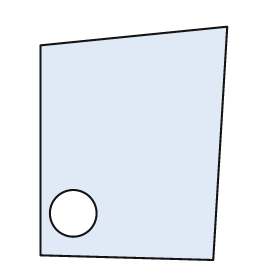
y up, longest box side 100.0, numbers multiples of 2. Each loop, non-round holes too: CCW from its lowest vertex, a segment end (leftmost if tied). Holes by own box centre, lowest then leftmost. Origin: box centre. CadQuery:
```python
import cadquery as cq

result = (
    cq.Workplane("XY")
    .moveTo(34.0, -50.0)
    .lineTo(40.0, 50.0)
    .lineTo(-40.0, 42.0)
    .lineTo(-40.0, -48.0)
    .close()
    .moveTo(-26.0, -30.0)
    .circle(10.0)
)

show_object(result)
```